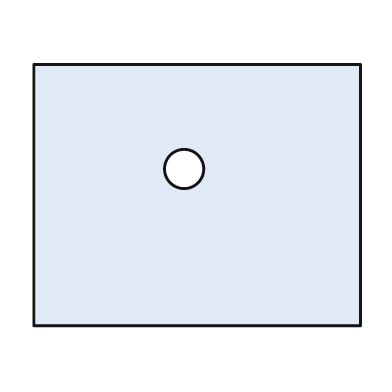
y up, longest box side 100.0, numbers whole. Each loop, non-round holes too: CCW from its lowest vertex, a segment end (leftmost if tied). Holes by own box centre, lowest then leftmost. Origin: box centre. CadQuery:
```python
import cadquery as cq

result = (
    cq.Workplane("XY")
    .moveTo(-50.0, -40.0)
    .lineTo(50.0, -40.0)
    .lineTo(50.0, 40.0)
    .lineTo(-50.0, 40.0)
    .close()
    .moveTo(-4.0, 8.0)
    .circle(6.0)
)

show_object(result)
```